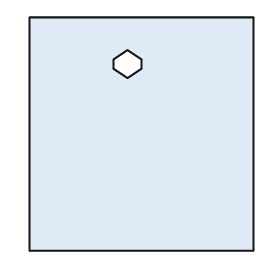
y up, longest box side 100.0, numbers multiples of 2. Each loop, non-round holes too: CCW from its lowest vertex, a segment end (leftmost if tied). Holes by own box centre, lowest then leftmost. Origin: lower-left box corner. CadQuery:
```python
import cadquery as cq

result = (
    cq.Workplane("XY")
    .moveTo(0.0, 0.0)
    .lineTo(96.0, 0.0)
    .lineTo(96.0, 100.0)
    .lineTo(0.0, 100.0)
    .close()
    .moveTo(42.0, 74.0)
    .lineTo(48.0, 78.0)
    .lineTo(48.0, 82.0)
    .lineTo(42.0, 86.0)
    .lineTo(36.0, 82.0)
    .lineTo(36.0, 78.0)
    .close()
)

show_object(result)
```